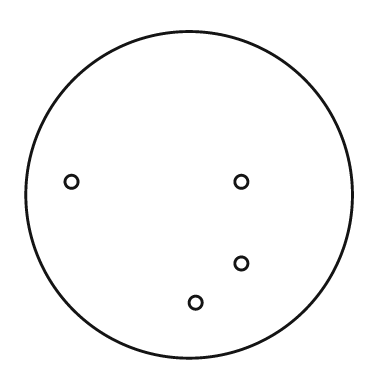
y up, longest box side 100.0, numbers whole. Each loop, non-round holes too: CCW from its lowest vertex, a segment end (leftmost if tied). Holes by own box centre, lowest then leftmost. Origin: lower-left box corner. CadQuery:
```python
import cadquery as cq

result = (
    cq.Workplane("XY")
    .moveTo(50.0, 50.0)
    .circle(50.0)
    .moveTo(52.0, 17.0)
    .circle(2.0)
    .moveTo(66.0, 29.0)
    .circle(2.0)
    .moveTo(14.0, 54.0)
    .circle(2.0)
    .moveTo(66.0, 54.0)
    .circle(2.0)
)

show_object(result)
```